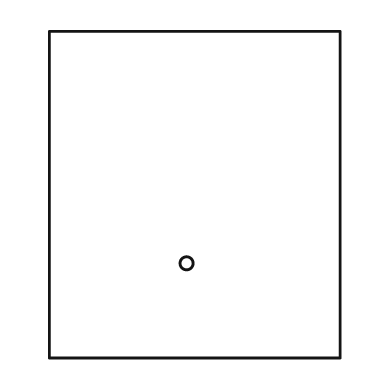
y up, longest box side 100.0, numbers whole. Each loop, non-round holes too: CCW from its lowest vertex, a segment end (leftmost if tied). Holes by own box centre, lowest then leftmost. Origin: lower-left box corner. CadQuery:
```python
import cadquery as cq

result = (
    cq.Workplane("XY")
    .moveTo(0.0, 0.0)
    .lineTo(89.0, 0.0)
    .lineTo(89.0, 100.0)
    .lineTo(0.0, 100.0)
    .close()
    .moveTo(42.0, 29.0)
    .circle(2.0)
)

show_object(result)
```